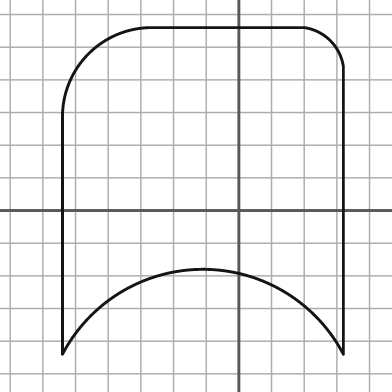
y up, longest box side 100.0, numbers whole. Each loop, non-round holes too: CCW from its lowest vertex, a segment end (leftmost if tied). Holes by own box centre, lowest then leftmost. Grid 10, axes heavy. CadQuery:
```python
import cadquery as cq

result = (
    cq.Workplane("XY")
    .moveTo(-54.0, -44.0)
    .threePointArc((-11.0, -18.0), (32.0, -44.0))
    .lineTo(32.0, 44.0)
    .threePointArc((28.0, 52.0), (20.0, 56.0))
    .lineTo(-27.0, 56.0)
    .threePointArc((-46.0, 48.0), (-54.0, 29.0))
    .close()
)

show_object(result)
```